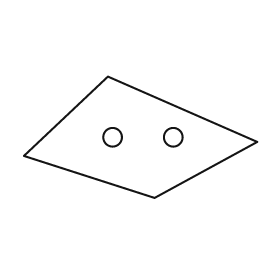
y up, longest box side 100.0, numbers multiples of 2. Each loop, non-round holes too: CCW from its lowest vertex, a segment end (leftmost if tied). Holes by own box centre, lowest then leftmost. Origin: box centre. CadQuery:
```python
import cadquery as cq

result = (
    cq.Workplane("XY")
    .moveTo(6.0, -26.0)
    .lineTo(50.0, -2.0)
    .lineTo(-14.0, 26.0)
    .lineTo(-50.0, -8.0)
    .close()
    .moveTo(-12.0, 0.0)
    .circle(4.0)
    .moveTo(14.0, 0.0)
    .circle(4.0)
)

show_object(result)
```